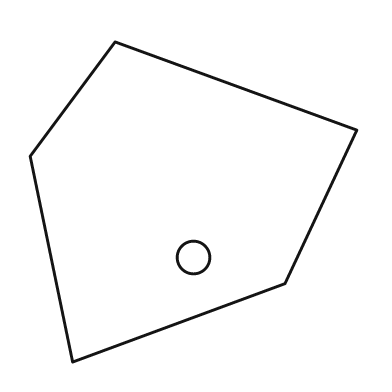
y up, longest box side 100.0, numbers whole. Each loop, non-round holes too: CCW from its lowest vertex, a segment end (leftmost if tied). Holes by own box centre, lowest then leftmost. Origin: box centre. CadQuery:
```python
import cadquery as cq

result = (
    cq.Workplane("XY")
    .moveTo(-37.0, -49.0)
    .lineTo(28.0, -25.0)
    .lineTo(50.0, 22.0)
    .lineTo(-24.0, 49.0)
    .lineTo(-50.0, 14.0)
    .close()
    .moveTo(0.0, -17.0)
    .circle(5.0)
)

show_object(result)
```